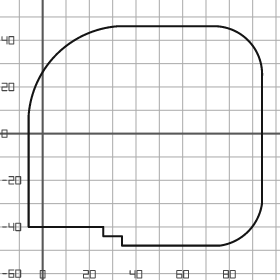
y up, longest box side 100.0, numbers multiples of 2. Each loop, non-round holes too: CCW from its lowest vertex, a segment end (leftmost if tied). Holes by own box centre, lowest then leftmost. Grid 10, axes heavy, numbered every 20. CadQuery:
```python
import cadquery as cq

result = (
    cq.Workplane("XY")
    .moveTo(34.0, -48.0)
    .lineTo(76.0, -48.0)
    .threePointArc((88.0, -42.0), (94.0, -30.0))
    .lineTo(94.0, 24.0)
    .threePointArc((88.0, 40.0), (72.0, 46.0))
    .lineTo(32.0, 46.0)
    .threePointArc((6.0, 34.0), (-6.0, 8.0))
    .lineTo(-6.0, -40.0)
    .lineTo(26.0, -40.0)
    .lineTo(26.0, -44.0)
    .lineTo(34.0, -44.0)
    .close()
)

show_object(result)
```